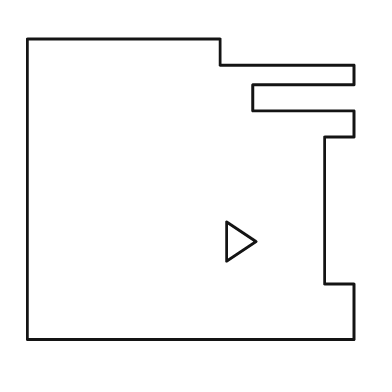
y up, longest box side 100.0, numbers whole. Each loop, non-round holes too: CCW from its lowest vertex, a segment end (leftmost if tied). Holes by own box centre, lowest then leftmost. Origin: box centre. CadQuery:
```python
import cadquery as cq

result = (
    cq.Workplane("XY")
    .moveTo(-50.0, -46.0)
    .lineTo(50.0, -46.0)
    .lineTo(50.0, -29.0)
    .lineTo(41.0, -29.0)
    .lineTo(41.0, 16.0)
    .lineTo(50.0, 16.0)
    .lineTo(50.0, 24.0)
    .lineTo(19.0, 24.0)
    .lineTo(19.0, 32.0)
    .lineTo(50.0, 32.0)
    .lineTo(50.0, 38.0)
    .lineTo(9.0, 38.0)
    .lineTo(9.0, 46.0)
    .lineTo(-50.0, 46.0)
    .close()
    .moveTo(11.0, -22.0)
    .lineTo(20.0, -16.0)
    .lineTo(11.0, -10.0)
    .close()
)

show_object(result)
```